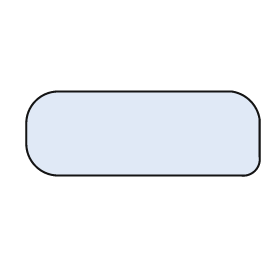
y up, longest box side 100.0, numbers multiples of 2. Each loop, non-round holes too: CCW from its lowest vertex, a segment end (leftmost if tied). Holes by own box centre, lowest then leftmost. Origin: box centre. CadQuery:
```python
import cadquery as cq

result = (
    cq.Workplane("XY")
    .moveTo(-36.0, -18.0)
    .lineTo(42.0, -18.0)
    .threePointArc((48.0, -16.0), (50.0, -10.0))
    .lineTo(50.0, 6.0)
    .threePointArc((46.0, 14.0), (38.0, 18.0))
    .lineTo(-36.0, 18.0)
    .threePointArc((-46.0, 14.0), (-50.0, 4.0))
    .lineTo(-50.0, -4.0)
    .threePointArc((-46.0, -14.0), (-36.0, -18.0))
    .close()
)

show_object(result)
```